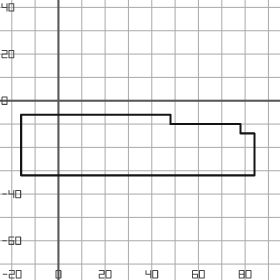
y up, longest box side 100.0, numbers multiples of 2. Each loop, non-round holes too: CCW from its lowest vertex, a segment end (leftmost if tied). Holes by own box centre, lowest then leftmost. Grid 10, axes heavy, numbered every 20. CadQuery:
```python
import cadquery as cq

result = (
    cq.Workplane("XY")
    .moveTo(-16.0, -32.0)
    .lineTo(84.0, -32.0)
    .lineTo(84.0, -14.0)
    .lineTo(78.0, -14.0)
    .lineTo(78.0, -10.0)
    .lineTo(48.0, -10.0)
    .lineTo(48.0, -6.0)
    .lineTo(-16.0, -6.0)
    .close()
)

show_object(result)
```